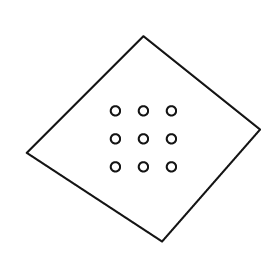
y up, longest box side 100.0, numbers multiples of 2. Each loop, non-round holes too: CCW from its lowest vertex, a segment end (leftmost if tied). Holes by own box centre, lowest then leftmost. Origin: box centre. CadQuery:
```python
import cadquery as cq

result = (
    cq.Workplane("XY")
    .moveTo(8.0, -44.0)
    .lineTo(50.0, 4.0)
    .lineTo(0.0, 44.0)
    .lineTo(-50.0, -6.0)
    .close()
    .moveTo(-12.0, -12.0)
    .circle(2.0)
    .moveTo(0.0, -12.0)
    .circle(2.0)
    .moveTo(12.0, -12.0)
    .circle(2.0)
    .moveTo(-12.0, 0.0)
    .circle(2.0)
    .moveTo(0.0, 0.0)
    .circle(2.0)
    .moveTo(12.0, 0.0)
    .circle(2.0)
    .moveTo(-12.0, 12.0)
    .circle(2.0)
    .moveTo(0.0, 12.0)
    .circle(2.0)
    .moveTo(12.0, 12.0)
    .circle(2.0)
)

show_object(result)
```